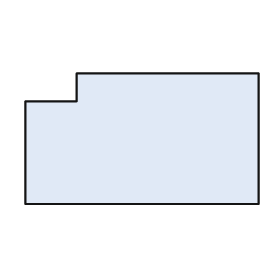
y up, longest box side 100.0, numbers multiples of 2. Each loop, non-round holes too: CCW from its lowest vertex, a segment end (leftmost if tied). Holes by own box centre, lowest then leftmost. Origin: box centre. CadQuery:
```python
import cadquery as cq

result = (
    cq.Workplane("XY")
    .moveTo(-50.0, -28.0)
    .lineTo(50.0, -28.0)
    .lineTo(50.0, 28.0)
    .lineTo(-28.0, 28.0)
    .lineTo(-28.0, 16.0)
    .lineTo(-50.0, 16.0)
    .close()
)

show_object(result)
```